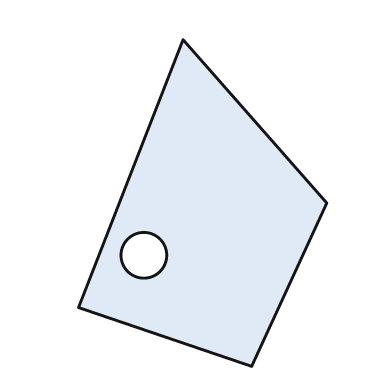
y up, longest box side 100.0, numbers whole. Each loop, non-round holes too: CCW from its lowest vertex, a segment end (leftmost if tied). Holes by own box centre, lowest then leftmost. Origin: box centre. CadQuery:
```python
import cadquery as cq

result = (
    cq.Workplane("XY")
    .moveTo(15.0, -50.0)
    .lineTo(38.0, 0.0)
    .lineTo(-6.0, 50.0)
    .lineTo(-38.0, -32.0)
    .close()
    .moveTo(-18.0, -16.0)
    .circle(7.0)
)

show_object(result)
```